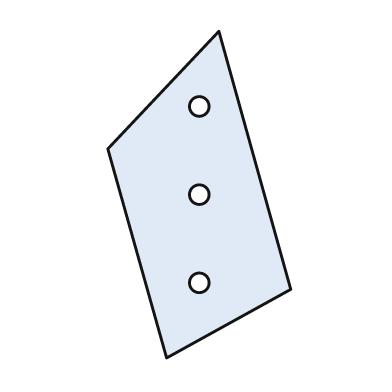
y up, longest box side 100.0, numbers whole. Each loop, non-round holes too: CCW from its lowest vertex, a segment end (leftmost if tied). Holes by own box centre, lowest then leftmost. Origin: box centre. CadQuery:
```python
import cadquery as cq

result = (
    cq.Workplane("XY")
    .moveTo(-10.0, -50.0)
    .lineTo(28.0, -29.0)
    .lineTo(6.0, 50.0)
    .lineTo(-28.0, 14.0)
    .close()
    .moveTo(0.0, -27.0)
    .circle(3.0)
    .moveTo(0.0, 0.0)
    .circle(3.0)
    .moveTo(0.0, 27.0)
    .circle(3.0)
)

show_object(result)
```